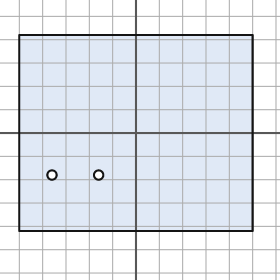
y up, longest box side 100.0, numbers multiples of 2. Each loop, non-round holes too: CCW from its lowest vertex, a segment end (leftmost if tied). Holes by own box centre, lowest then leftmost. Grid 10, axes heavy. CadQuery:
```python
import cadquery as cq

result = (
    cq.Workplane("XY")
    .moveTo(-50.0, -42.0)
    .lineTo(50.0, -42.0)
    .lineTo(50.0, 42.0)
    .lineTo(-50.0, 42.0)
    .close()
    .moveTo(-36.0, -18.0)
    .circle(2.0)
    .moveTo(-16.0, -18.0)
    .circle(2.0)
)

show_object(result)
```